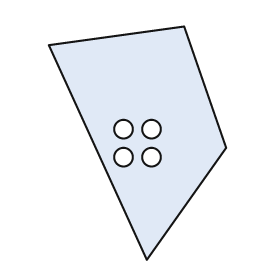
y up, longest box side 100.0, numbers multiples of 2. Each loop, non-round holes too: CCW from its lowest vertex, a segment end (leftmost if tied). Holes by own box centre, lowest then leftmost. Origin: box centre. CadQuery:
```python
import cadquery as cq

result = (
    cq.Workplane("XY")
    .moveTo(4.0, -50.0)
    .lineTo(38.0, -2.0)
    .lineTo(20.0, 50.0)
    .lineTo(-38.0, 42.0)
    .close()
    .moveTo(-6.0, -6.0)
    .circle(4.0)
    .moveTo(6.0, -6.0)
    .circle(4.0)
    .moveTo(-6.0, 6.0)
    .circle(4.0)
    .moveTo(6.0, 6.0)
    .circle(4.0)
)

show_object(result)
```